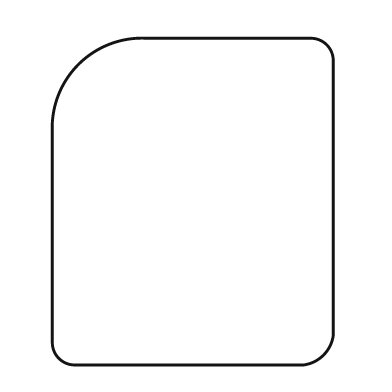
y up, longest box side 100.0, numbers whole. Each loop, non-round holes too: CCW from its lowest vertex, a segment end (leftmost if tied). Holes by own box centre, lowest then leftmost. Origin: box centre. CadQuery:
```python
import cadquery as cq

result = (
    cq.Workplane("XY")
    .moveTo(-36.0, -50.0)
    .lineTo(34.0, -50.0)
    .threePointArc((40.0, -47.0), (43.0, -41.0))
    .lineTo(43.0, 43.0)
    .threePointArc((41.0, 48.0), (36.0, 50.0))
    .lineTo(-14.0, 50.0)
    .threePointArc((-35.0, 42.0), (-43.0, 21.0))
    .lineTo(-43.0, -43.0)
    .threePointArc((-41.0, -48.0), (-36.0, -50.0))
    .close()
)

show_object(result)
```